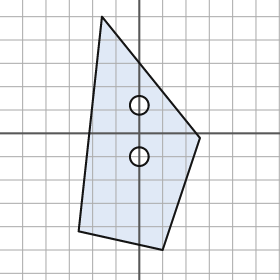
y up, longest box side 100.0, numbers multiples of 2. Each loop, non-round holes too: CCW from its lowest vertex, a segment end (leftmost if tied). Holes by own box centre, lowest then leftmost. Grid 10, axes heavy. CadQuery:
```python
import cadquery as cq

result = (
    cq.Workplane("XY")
    .moveTo(10.0, -50.0)
    .lineTo(26.0, -2.0)
    .lineTo(-16.0, 50.0)
    .lineTo(-26.0, -42.0)
    .close()
    .moveTo(0.0, -10.0)
    .circle(4.0)
    .moveTo(0.0, 12.0)
    .circle(4.0)
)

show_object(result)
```